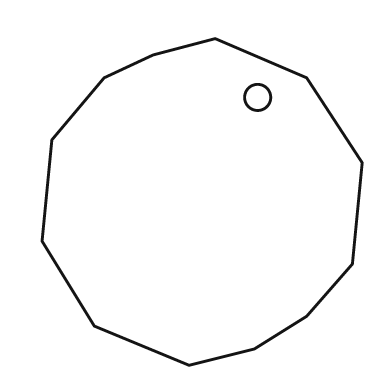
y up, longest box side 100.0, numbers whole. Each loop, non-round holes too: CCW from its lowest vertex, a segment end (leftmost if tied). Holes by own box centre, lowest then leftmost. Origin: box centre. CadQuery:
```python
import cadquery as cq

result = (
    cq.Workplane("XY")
    .moveTo(-4.0, -50.0)
    .lineTo(16.0, -45.0)
    .lineTo(32.0, -35.0)
    .lineTo(46.0, -19.0)
    .lineTo(49.0, 12.0)
    .lineTo(32.0, 38.0)
    .lineTo(4.0, 50.0)
    .lineTo(-15.0, 45.0)
    .lineTo(-30.0, 38.0)
    .lineTo(-46.0, 19.0)
    .lineTo(-49.0, -12.0)
    .lineTo(-33.0, -38.0)
    .close()
    .moveTo(17.0, 32.0)
    .circle(4.0)
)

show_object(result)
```